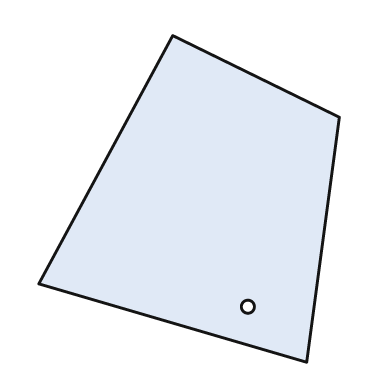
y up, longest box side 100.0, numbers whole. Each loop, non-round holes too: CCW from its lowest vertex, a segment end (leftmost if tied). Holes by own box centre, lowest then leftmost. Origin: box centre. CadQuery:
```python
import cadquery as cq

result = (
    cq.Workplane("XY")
    .moveTo(36.0, -50.0)
    .lineTo(46.0, 25.0)
    .lineTo(-5.0, 50.0)
    .lineTo(-46.0, -26.0)
    .close()
    .moveTo(18.0, -33.0)
    .circle(2.0)
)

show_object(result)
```